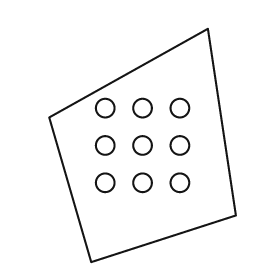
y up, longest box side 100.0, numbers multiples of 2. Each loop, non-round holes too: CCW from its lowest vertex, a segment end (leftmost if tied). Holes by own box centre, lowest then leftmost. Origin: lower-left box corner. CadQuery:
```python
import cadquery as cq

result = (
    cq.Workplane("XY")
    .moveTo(18.0, 0.0)
    .lineTo(80.0, 20.0)
    .lineTo(68.0, 100.0)
    .lineTo(0.0, 62.0)
    .close()
    .moveTo(24.0, 34.0)
    .circle(4.0)
    .moveTo(40.0, 34.0)
    .circle(4.0)
    .moveTo(56.0, 34.0)
    .circle(4.0)
    .moveTo(24.0, 50.0)
    .circle(4.0)
    .moveTo(40.0, 50.0)
    .circle(4.0)
    .moveTo(56.0, 50.0)
    .circle(4.0)
    .moveTo(24.0, 66.0)
    .circle(4.0)
    .moveTo(40.0, 66.0)
    .circle(4.0)
    .moveTo(56.0, 66.0)
    .circle(4.0)
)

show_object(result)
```